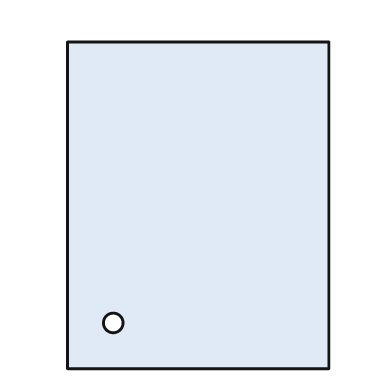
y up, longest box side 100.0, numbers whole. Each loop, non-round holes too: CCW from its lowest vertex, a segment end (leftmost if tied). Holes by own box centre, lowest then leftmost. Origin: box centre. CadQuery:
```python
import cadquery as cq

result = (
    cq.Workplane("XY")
    .moveTo(-40.0, -50.0)
    .lineTo(40.0, -50.0)
    .lineTo(40.0, 50.0)
    .lineTo(-40.0, 50.0)
    .close()
    .moveTo(-26.0, -36.0)
    .circle(3.0)
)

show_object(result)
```